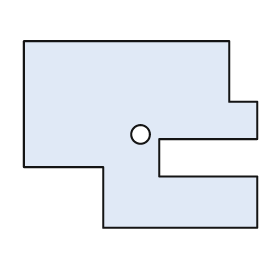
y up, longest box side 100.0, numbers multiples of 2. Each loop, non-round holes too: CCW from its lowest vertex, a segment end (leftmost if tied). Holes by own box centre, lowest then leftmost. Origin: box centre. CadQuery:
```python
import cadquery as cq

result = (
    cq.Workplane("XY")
    .moveTo(-16.0, -40.0)
    .lineTo(50.0, -40.0)
    .lineTo(50.0, -18.0)
    .lineTo(8.0, -18.0)
    .lineTo(8.0, -2.0)
    .lineTo(50.0, -2.0)
    .lineTo(50.0, 14.0)
    .lineTo(38.0, 14.0)
    .lineTo(38.0, 40.0)
    .lineTo(-50.0, 40.0)
    .lineTo(-50.0, -14.0)
    .lineTo(-16.0, -14.0)
    .close()
    .moveTo(0.0, 0.0)
    .circle(4.0)
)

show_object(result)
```